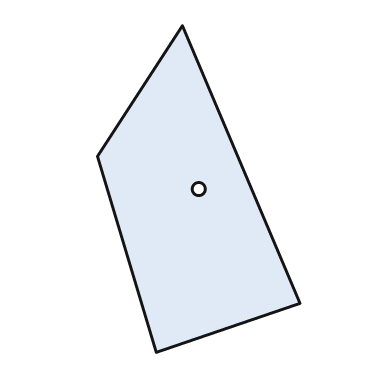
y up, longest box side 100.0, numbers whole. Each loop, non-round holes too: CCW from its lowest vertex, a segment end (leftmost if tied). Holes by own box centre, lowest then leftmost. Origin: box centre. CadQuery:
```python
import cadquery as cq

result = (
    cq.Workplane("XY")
    .moveTo(-13.0, -50.0)
    .lineTo(31.0, -35.0)
    .lineTo(-5.0, 50.0)
    .lineTo(-31.0, 10.0)
    .close()
    .moveTo(0.0, 0.0)
    .circle(2.0)
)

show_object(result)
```